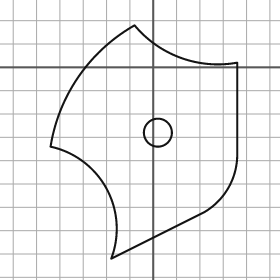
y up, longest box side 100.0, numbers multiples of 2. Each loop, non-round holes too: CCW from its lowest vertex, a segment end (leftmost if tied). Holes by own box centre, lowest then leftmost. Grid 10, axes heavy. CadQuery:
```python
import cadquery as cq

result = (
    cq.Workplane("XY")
    .moveTo(-18.0, -82.0)
    .lineTo(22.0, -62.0)
    .threePointArc((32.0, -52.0), (36.0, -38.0))
    .lineTo(36.0, 2.0)
    .threePointArc((12.0, 4.0), (-8.0, 18.0))
    .threePointArc((-32.0, -4.0), (-44.0, -34.0))
    .threePointArc((-20.0, -52.0), (-18.0, -82.0))
    .close()
    .moveTo(2.0, -28.0)
    .circle(6.0)
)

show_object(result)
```